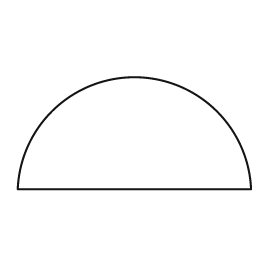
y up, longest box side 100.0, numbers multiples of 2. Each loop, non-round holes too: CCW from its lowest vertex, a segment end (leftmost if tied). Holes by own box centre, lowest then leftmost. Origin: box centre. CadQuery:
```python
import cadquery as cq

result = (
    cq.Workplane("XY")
    .moveTo(-50.0, -24.0)
    .lineTo(50.0, -24.0)
    .threePointArc((0.0, 24.0), (-50.0, -24.0))
    .close()
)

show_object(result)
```